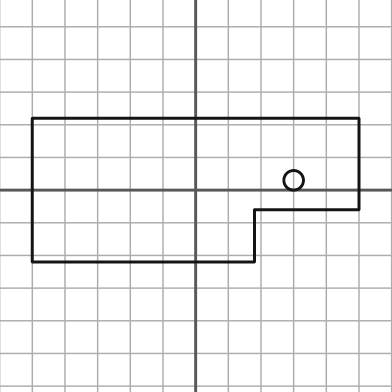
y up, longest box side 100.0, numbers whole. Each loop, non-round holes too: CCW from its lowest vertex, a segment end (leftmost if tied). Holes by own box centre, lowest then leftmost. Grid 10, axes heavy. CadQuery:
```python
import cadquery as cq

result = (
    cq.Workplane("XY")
    .moveTo(-50.0, -22.0)
    .lineTo(18.0, -22.0)
    .lineTo(18.0, -6.0)
    .lineTo(50.0, -6.0)
    .lineTo(50.0, 22.0)
    .lineTo(-50.0, 22.0)
    .close()
    .moveTo(30.0, 3.0)
    .circle(3.0)
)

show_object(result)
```